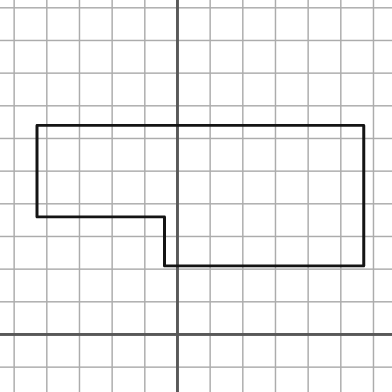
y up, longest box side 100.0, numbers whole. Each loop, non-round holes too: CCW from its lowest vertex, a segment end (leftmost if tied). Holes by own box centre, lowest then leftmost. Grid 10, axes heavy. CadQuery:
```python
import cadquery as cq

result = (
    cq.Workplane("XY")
    .moveTo(-4.0, 21.0)
    .lineTo(57.0, 21.0)
    .lineTo(57.0, 64.0)
    .lineTo(-43.0, 64.0)
    .lineTo(-43.0, 36.0)
    .lineTo(-4.0, 36.0)
    .close()
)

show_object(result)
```